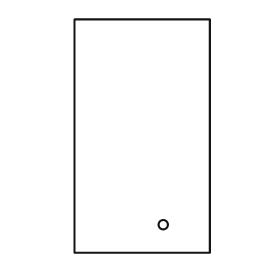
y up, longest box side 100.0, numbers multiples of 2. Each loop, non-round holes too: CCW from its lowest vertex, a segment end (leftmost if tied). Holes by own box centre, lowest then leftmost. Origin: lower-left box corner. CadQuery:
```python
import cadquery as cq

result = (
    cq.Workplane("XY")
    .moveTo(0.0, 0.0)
    .lineTo(58.0, 0.0)
    .lineTo(58.0, 100.0)
    .lineTo(0.0, 100.0)
    .close()
    .moveTo(38.0, 12.0)
    .circle(2.0)
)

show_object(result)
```